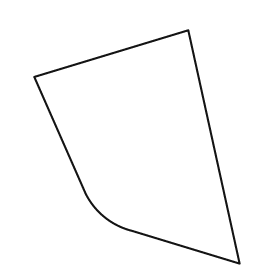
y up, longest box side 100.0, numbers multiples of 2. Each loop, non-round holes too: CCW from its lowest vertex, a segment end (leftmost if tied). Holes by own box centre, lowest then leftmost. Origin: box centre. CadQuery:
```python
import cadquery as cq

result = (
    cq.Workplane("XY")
    .moveTo(44.0, -50.0)
    .lineTo(22.0, 50.0)
    .lineTo(-44.0, 30.0)
    .lineTo(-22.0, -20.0)
    .threePointArc((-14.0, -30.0), (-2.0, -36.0))
    .close()
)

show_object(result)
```